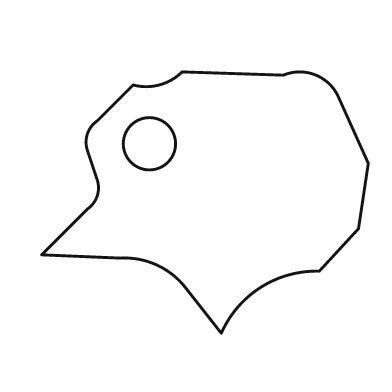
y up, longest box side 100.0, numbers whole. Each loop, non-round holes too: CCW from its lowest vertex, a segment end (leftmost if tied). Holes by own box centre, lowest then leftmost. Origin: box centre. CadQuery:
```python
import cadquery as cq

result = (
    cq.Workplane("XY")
    .moveTo(5.0, -40.0)
    .threePointArc((17.0, -26.0), (35.0, -21.0))
    .lineTo(47.0, -8.0)
    .lineTo(50.0, 12.0)
    .lineTo(41.0, 32.0)
    .threePointArc((34.0, 39.0), (24.0, 39.0))
    .lineTo(-7.0, 40.0)
    .threePointArc((-14.0, 36.0), (-22.0, 36.0))
    .lineTo(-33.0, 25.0)
    .threePointArc((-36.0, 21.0), (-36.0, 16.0))
    .lineTo(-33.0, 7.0)
    .threePointArc((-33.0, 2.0), (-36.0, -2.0))
    .lineTo(-50.0, -16.0)
    .lineTo(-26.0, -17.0)
    .threePointArc((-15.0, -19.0), (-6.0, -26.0))
    .close()
    .moveTo(-17.0, 18.0)
    .circle(8.0)
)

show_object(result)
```